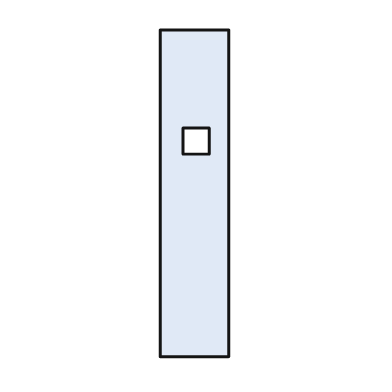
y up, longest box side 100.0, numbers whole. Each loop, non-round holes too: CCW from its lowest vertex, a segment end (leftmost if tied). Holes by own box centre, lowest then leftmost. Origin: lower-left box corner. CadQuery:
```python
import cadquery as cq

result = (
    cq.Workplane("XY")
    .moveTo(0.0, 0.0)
    .lineTo(21.0, 0.0)
    .lineTo(21.0, 100.0)
    .lineTo(0.0, 100.0)
    .close()
    .moveTo(7.0, 62.0)
    .lineTo(15.0, 62.0)
    .lineTo(15.0, 70.0)
    .lineTo(7.0, 70.0)
    .close()
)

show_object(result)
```